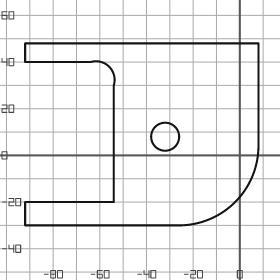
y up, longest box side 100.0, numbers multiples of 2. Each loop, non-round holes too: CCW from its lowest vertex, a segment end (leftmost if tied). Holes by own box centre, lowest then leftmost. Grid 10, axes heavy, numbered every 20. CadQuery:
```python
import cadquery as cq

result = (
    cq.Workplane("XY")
    .moveTo(-92.0, -30.0)
    .lineTo(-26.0, -30.0)
    .threePointArc((-2.0, -20.0), (8.0, 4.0))
    .lineTo(8.0, 48.0)
    .lineTo(-92.0, 48.0)
    .lineTo(-92.0, 40.0)
    .lineTo(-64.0, 40.0)
    .threePointArc((-56.0, 38.0), (-54.0, 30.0))
    .lineTo(-54.0, -20.0)
    .lineTo(-92.0, -20.0)
    .close()
    .moveTo(-32.0, 8.0)
    .circle(6.0)
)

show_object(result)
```